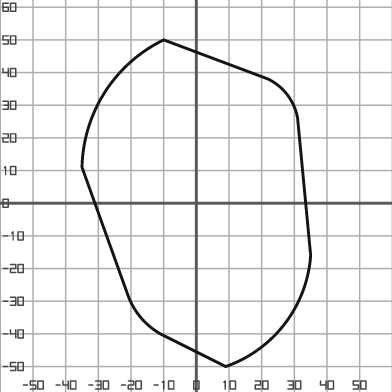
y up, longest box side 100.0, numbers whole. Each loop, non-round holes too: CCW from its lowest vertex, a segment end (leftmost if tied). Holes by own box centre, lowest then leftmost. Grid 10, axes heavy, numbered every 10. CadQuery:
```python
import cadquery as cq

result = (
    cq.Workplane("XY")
    .moveTo(9.0, -50.0)
    .threePointArc((27.0, -37.0), (35.0, -16.0))
    .lineTo(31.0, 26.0)
    .threePointArc((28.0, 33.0), (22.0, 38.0))
    .lineTo(-10.0, 50.0)
    .threePointArc((-28.0, 34.0), (-35.0, 11.0))
    .lineTo(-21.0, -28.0)
    .threePointArc((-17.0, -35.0), (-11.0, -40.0))
    .close()
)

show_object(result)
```